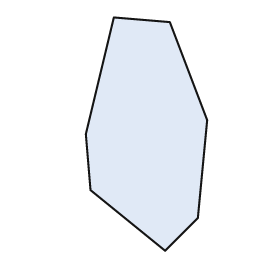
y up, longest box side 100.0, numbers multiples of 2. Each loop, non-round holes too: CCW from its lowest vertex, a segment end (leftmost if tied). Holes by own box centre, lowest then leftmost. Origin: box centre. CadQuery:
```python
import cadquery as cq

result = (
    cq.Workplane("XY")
    .moveTo(8.0, -50.0)
    .lineTo(22.0, -36.0)
    .lineTo(26.0, 6.0)
    .lineTo(10.0, 48.0)
    .lineTo(-14.0, 50.0)
    .lineTo(-26.0, 0.0)
    .lineTo(-24.0, -24.0)
    .close()
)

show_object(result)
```